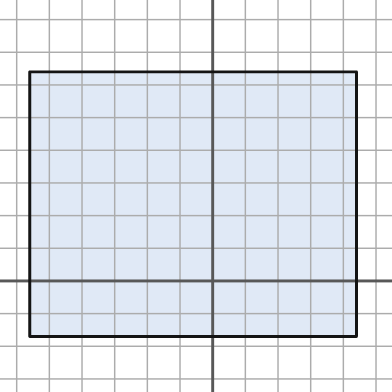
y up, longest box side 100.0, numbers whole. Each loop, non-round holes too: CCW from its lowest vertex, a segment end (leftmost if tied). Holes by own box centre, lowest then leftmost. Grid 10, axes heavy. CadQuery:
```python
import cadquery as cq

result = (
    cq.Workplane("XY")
    .moveTo(-56.0, -17.0)
    .lineTo(44.0, -17.0)
    .lineTo(44.0, 64.0)
    .lineTo(-56.0, 64.0)
    .close()
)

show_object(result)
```